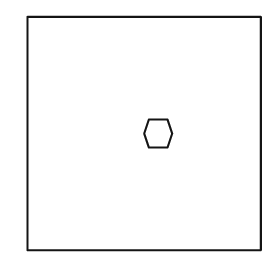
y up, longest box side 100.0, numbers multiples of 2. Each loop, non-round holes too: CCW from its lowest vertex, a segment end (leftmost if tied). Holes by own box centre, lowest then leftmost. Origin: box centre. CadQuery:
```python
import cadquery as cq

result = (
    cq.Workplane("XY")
    .moveTo(-50.0, -50.0)
    .lineTo(50.0, -50.0)
    .lineTo(50.0, 50.0)
    .lineTo(-50.0, 50.0)
    .close()
    .moveTo(2.0, -6.0)
    .lineTo(10.0, -6.0)
    .lineTo(12.0, 0.0)
    .lineTo(10.0, 6.0)
    .lineTo(2.0, 6.0)
    .lineTo(0.0, 0.0)
    .close()
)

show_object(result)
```